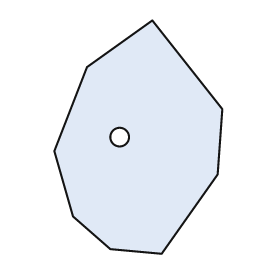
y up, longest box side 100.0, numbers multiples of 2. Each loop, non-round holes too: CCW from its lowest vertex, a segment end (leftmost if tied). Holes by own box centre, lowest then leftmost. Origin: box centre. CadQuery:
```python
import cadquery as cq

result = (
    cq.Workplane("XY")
    .moveTo(10.0, -50.0)
    .lineTo(34.0, -16.0)
    .lineTo(36.0, 12.0)
    .lineTo(6.0, 50.0)
    .lineTo(-22.0, 30.0)
    .lineTo(-36.0, -6.0)
    .lineTo(-28.0, -34.0)
    .lineTo(-12.0, -48.0)
    .close()
    .moveTo(-8.0, 0.0)
    .circle(4.0)
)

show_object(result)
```